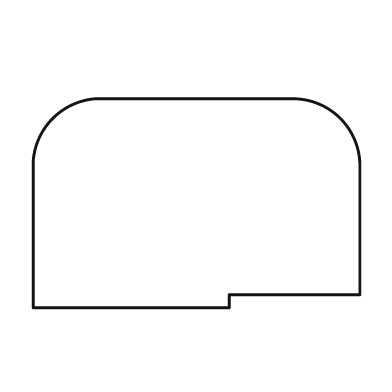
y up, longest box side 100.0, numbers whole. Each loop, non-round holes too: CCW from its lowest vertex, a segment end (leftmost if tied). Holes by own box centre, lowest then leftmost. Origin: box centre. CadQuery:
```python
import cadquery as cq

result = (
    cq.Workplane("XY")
    .moveTo(-50.0, -32.0)
    .lineTo(10.0, -32.0)
    .lineTo(10.0, -28.0)
    .lineTo(50.0, -28.0)
    .lineTo(50.0, 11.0)
    .threePointArc((44.0, 26.0), (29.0, 32.0))
    .lineTo(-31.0, 32.0)
    .threePointArc((-44.0, 26.0), (-50.0, 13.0))
    .close()
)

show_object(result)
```